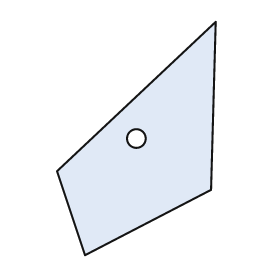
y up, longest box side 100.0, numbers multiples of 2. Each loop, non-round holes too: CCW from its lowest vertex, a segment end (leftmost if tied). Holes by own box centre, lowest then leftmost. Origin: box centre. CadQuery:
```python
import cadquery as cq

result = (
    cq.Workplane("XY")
    .moveTo(-22.0, -50.0)
    .lineTo(32.0, -22.0)
    .lineTo(34.0, 50.0)
    .lineTo(-34.0, -14.0)
    .close()
    .moveTo(0.0, 0.0)
    .circle(4.0)
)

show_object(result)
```